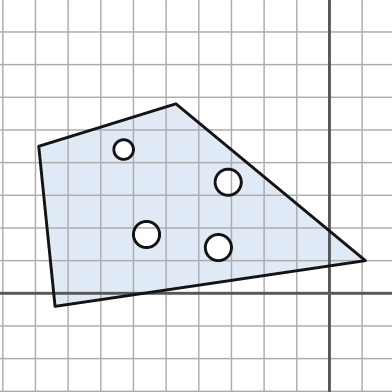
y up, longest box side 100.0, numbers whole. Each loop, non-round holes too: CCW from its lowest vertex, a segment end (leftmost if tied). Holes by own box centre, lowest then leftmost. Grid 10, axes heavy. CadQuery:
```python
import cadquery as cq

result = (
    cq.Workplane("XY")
    .moveTo(-84.0, -4.0)
    .lineTo(11.0, 10.0)
    .lineTo(-47.0, 58.0)
    .lineTo(-89.0, 45.0)
    .close()
    .moveTo(-34.0, 14.0)
    .circle(4.0)
    .moveTo(-56.0, 18.0)
    .circle(4.0)
    .moveTo(-31.0, 34.0)
    .circle(4.0)
    .moveTo(-63.0, 44.0)
    .circle(3.0)
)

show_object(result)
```